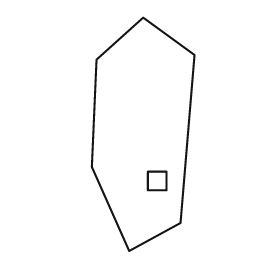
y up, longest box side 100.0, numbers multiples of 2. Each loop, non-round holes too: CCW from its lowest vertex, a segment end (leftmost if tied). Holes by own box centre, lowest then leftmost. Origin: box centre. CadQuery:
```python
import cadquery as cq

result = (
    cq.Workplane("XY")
    .moveTo(-6.0, -50.0)
    .lineTo(16.0, -38.0)
    .lineTo(22.0, 34.0)
    .lineTo(0.0, 50.0)
    .lineTo(-20.0, 32.0)
    .lineTo(-22.0, -14.0)
    .close()
    .moveTo(2.0, -24.0)
    .lineTo(10.0, -24.0)
    .lineTo(10.0, -16.0)
    .lineTo(2.0, -16.0)
    .close()
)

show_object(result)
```